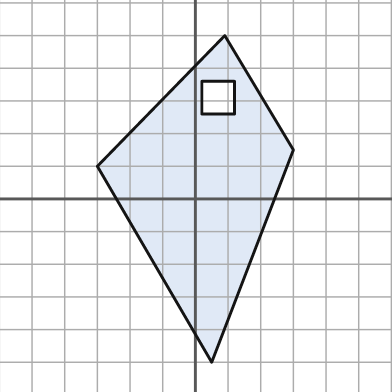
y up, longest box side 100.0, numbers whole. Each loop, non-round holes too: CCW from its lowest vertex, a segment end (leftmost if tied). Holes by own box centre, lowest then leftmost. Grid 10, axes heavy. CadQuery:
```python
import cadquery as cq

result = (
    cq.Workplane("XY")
    .moveTo(5.0, -50.0)
    .lineTo(30.0, 15.0)
    .lineTo(9.0, 50.0)
    .lineTo(-30.0, 10.0)
    .close()
    .moveTo(2.0, 26.0)
    .lineTo(12.0, 26.0)
    .lineTo(12.0, 36.0)
    .lineTo(2.0, 36.0)
    .close()
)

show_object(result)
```